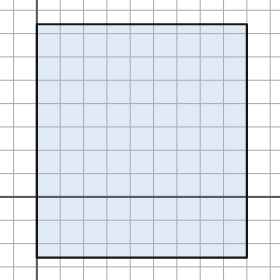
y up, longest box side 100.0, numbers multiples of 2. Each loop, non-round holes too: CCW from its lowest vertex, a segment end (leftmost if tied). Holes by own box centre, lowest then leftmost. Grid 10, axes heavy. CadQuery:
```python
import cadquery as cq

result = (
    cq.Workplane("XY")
    .moveTo(0.0, -26.0)
    .lineTo(90.0, -26.0)
    .lineTo(90.0, 74.0)
    .lineTo(0.0, 74.0)
    .close()
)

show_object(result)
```